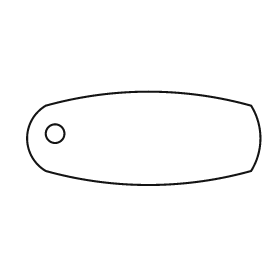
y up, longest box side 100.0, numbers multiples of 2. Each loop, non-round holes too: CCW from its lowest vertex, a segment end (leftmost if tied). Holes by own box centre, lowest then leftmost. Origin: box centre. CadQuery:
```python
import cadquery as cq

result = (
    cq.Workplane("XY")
    .moveTo(-42.0, -14.0)
    .threePointArc((2.0, -20.0), (46.0, -14.0))
    .threePointArc((50.0, 0.0), (46.0, 14.0))
    .threePointArc((2.0, 20.0), (-42.0, 14.0))
    .threePointArc((-50.0, 0.0), (-42.0, -14.0))
    .close()
    .moveTo(-38.0, 2.0)
    .circle(4.0)
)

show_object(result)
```